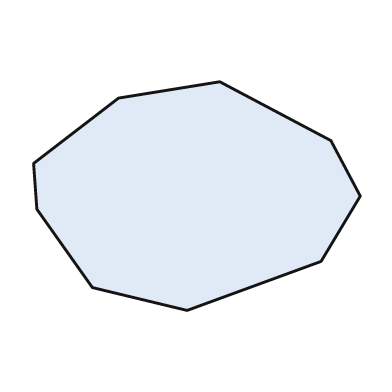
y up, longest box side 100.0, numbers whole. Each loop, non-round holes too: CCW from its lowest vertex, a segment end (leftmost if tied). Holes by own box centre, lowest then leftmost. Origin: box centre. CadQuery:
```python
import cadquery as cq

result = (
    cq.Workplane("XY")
    .moveTo(-3.0, -35.0)
    .lineTo(38.0, -20.0)
    .lineTo(50.0, 0.0)
    .lineTo(41.0, 17.0)
    .lineTo(7.0, 35.0)
    .lineTo(-24.0, 30.0)
    .lineTo(-50.0, 10.0)
    .lineTo(-49.0, -4.0)
    .lineTo(-32.0, -28.0)
    .close()
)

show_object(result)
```